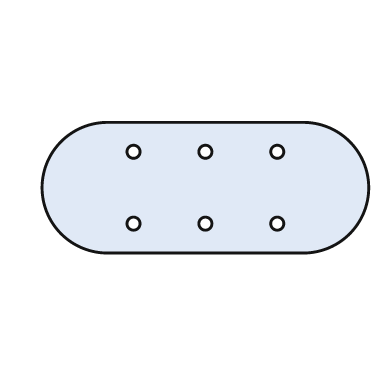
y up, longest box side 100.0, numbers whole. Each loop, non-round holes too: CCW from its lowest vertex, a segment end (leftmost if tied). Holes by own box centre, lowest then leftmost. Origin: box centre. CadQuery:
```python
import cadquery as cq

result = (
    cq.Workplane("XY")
    .moveTo(-30.0, -20.0)
    .lineTo(30.0, -20.0)
    .threePointArc((50.0, 0.0), (30.0, 20.0))
    .lineTo(-30.0, 20.0)
    .threePointArc((-50.0, 0.0), (-30.0, -20.0))
    .close()
    .moveTo(-22.0, -11.0)
    .circle(2.0)
    .moveTo(0.0, -11.0)
    .circle(2.0)
    .moveTo(22.0, -11.0)
    .circle(2.0)
    .moveTo(-22.0, 11.0)
    .circle(2.0)
    .moveTo(0.0, 11.0)
    .circle(2.0)
    .moveTo(22.0, 11.0)
    .circle(2.0)
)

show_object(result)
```